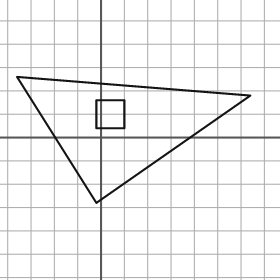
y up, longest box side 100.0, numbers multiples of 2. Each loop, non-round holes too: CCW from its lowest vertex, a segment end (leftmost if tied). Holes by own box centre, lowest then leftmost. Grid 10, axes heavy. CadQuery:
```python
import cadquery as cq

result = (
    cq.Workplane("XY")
    .moveTo(-2.0, -28.0)
    .lineTo(64.0, 18.0)
    .lineTo(-36.0, 26.0)
    .close()
    .moveTo(-2.0, 4.0)
    .lineTo(10.0, 4.0)
    .lineTo(10.0, 16.0)
    .lineTo(-2.0, 16.0)
    .close()
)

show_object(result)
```